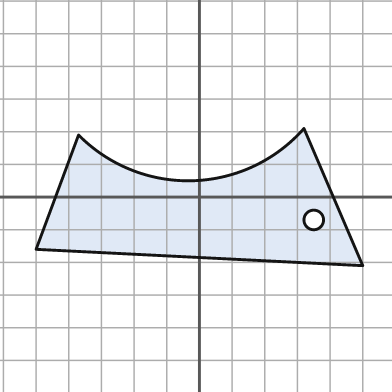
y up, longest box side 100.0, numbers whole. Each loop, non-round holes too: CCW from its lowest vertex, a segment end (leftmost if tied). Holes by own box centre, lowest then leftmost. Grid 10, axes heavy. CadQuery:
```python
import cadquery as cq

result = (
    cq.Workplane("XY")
    .moveTo(50.0, -21.0)
    .lineTo(32.0, 21.0)
    .threePointArc((-2.0, 5.0), (-37.0, 19.0))
    .lineTo(-50.0, -16.0)
    .close()
    .moveTo(35.0, -7.0)
    .circle(3.0)
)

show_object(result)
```